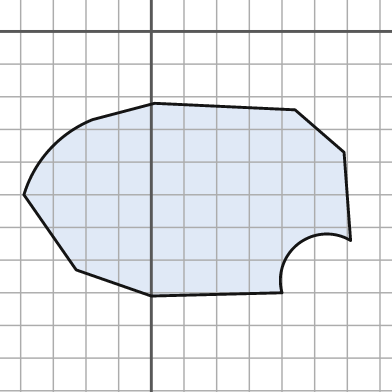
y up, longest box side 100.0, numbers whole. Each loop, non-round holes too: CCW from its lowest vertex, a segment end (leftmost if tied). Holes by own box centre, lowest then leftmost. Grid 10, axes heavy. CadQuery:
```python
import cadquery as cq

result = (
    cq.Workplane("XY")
    .moveTo(0.0, -81.0)
    .lineTo(40.0, -80.0)
    .threePointArc((45.0, -65.0), (61.0, -64.0))
    .lineTo(59.0, -37.0)
    .lineTo(44.0, -24.0)
    .lineTo(1.0, -22.0)
    .lineTo(-18.0, -27.0)
    .threePointArc((-31.0, -36.0), (-39.0, -50.0))
    .lineTo(-23.0, -73.0)
    .close()
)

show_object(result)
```